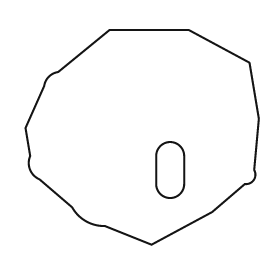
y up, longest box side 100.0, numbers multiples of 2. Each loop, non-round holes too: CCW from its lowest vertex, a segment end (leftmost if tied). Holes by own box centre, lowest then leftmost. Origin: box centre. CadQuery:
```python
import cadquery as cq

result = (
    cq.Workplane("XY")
    .moveTo(4.0, -46.0)
    .lineTo(30.0, -32.0)
    .lineTo(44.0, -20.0)
    .threePointArc((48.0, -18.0), (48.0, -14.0))
    .lineTo(50.0, 8.0)
    .lineTo(46.0, 32.0)
    .lineTo(20.0, 46.0)
    .lineTo(-14.0, 46.0)
    .lineTo(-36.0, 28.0)
    .threePointArc((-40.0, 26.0), (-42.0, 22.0))
    .lineTo(-50.0, 4.0)
    .lineTo(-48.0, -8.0)
    .threePointArc((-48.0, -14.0), (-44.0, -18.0))
    .lineTo(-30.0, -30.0)
    .threePointArc((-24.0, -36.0), (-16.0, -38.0))
    .close()
    .moveTo(6.0, -20.0)
    .threePointArc((12.0, -26.0), (18.0, -20.0))
    .lineTo(18.0, -8.0)
    .threePointArc((12.0, -2.0), (6.0, -8.0))
    .close()
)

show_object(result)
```